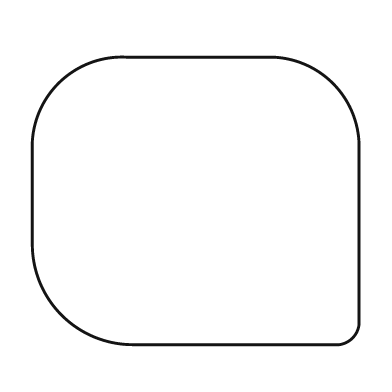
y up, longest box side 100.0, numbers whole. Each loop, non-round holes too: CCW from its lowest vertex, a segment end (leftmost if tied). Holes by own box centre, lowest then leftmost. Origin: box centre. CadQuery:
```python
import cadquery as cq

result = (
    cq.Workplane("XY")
    .moveTo(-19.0, -44.0)
    .lineTo(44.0, -44.0)
    .threePointArc((48.0, -42.0), (50.0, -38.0))
    .lineTo(50.0, 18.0)
    .threePointArc((42.0, 36.0), (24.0, 44.0))
    .lineTo(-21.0, 44.0)
    .threePointArc((-42.0, 36.0), (-50.0, 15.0))
    .lineTo(-50.0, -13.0)
    .threePointArc((-41.0, -35.0), (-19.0, -44.0))
    .close()
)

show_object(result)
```